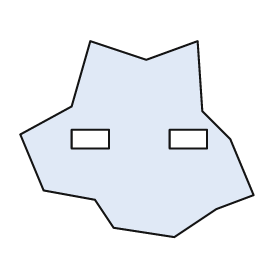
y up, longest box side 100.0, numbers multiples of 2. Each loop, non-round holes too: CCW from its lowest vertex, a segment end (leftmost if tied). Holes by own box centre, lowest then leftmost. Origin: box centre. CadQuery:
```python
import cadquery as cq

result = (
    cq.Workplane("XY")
    .moveTo(16.0, -42.0)
    .lineTo(34.0, -30.0)
    .lineTo(50.0, -24.0)
    .lineTo(40.0, 0.0)
    .lineTo(28.0, 12.0)
    .lineTo(26.0, 42.0)
    .lineTo(4.0, 34.0)
    .lineTo(-20.0, 42.0)
    .lineTo(-28.0, 14.0)
    .lineTo(-50.0, 2.0)
    .lineTo(-40.0, -22.0)
    .lineTo(-18.0, -26.0)
    .lineTo(-10.0, -38.0)
    .close()
    .moveTo(-28.0, -4.0)
    .lineTo(-12.0, -4.0)
    .lineTo(-12.0, 4.0)
    .lineTo(-28.0, 4.0)
    .close()
    .moveTo(14.0, -4.0)
    .lineTo(30.0, -4.0)
    .lineTo(30.0, 4.0)
    .lineTo(14.0, 4.0)
    .close()
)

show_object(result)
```